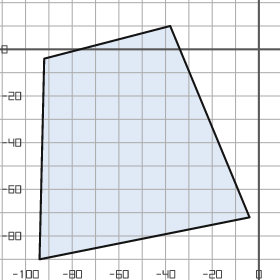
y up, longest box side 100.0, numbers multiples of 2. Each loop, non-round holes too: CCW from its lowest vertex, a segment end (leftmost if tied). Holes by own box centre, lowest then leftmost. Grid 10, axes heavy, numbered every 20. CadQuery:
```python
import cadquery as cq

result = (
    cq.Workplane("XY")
    .moveTo(-94.0, -90.0)
    .lineTo(-4.0, -72.0)
    .lineTo(-38.0, 10.0)
    .lineTo(-92.0, -4.0)
    .close()
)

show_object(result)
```